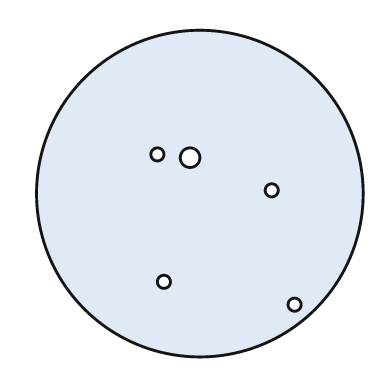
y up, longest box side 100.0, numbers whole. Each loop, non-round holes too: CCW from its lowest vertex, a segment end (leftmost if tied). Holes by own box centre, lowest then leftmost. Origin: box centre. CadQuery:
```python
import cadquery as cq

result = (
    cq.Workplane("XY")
    .moveTo(0.0, 0.0)
    .circle(50.0)
    .moveTo(29.0, -34.0)
    .circle(2.0)
    .moveTo(-11.0, -27.0)
    .circle(2.0)
    .moveTo(22.0, 1.0)
    .circle(2.0)
    .moveTo(-3.0, 11.0)
    .circle(3.0)
    .moveTo(-13.0, 12.0)
    .circle(2.0)
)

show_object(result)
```